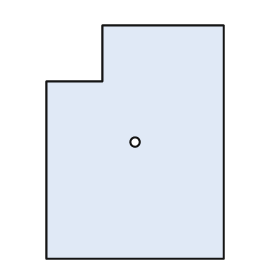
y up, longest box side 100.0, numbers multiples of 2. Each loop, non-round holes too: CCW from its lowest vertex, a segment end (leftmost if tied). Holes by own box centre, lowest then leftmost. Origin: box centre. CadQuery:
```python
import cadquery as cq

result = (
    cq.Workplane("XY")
    .moveTo(-38.0, -50.0)
    .lineTo(38.0, -50.0)
    .lineTo(38.0, 50.0)
    .lineTo(-14.0, 50.0)
    .lineTo(-14.0, 26.0)
    .lineTo(-38.0, 26.0)
    .close()
    .moveTo(0.0, 0.0)
    .circle(2.0)
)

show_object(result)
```